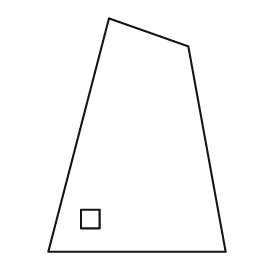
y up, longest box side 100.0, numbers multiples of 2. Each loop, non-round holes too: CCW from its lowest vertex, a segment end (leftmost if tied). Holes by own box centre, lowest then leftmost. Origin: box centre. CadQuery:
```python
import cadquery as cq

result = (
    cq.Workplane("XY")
    .moveTo(-38.0, -50.0)
    .lineTo(38.0, -50.0)
    .lineTo(22.0, 38.0)
    .lineTo(-12.0, 50.0)
    .close()
    .moveTo(-24.0, -40.0)
    .lineTo(-16.0, -40.0)
    .lineTo(-16.0, -32.0)
    .lineTo(-24.0, -32.0)
    .close()
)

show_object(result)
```